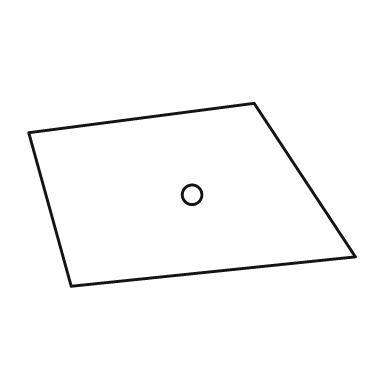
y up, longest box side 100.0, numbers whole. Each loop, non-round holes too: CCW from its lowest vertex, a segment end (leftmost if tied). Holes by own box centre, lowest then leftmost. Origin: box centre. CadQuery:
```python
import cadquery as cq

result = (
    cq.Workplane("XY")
    .moveTo(-37.0, -28.0)
    .lineTo(50.0, -19.0)
    .lineTo(19.0, 28.0)
    .lineTo(-50.0, 19.0)
    .close()
    .moveTo(0.0, 0.0)
    .circle(3.0)
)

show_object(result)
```